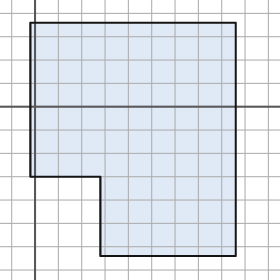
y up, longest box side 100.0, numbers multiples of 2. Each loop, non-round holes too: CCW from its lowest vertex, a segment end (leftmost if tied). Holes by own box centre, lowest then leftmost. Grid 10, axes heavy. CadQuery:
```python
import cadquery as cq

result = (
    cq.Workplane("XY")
    .moveTo(28.0, -64.0)
    .lineTo(86.0, -64.0)
    .lineTo(86.0, 36.0)
    .lineTo(-2.0, 36.0)
    .lineTo(-2.0, -30.0)
    .lineTo(28.0, -30.0)
    .close()
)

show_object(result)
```